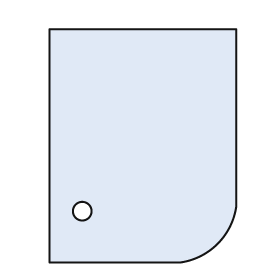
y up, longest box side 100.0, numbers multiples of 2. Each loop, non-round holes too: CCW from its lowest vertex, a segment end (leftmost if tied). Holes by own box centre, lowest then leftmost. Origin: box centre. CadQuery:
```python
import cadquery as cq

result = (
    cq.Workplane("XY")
    .moveTo(-40.0, -50.0)
    .lineTo(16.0, -50.0)
    .threePointArc((32.0, -42.0), (40.0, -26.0))
    .lineTo(40.0, 50.0)
    .lineTo(-40.0, 50.0)
    .close()
    .moveTo(-26.0, -28.0)
    .circle(4.0)
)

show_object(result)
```